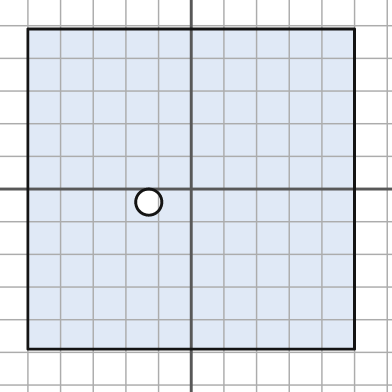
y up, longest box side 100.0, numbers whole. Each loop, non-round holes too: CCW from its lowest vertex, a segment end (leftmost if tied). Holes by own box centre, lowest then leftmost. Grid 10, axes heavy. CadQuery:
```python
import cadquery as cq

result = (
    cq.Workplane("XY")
    .moveTo(-50.0, -49.0)
    .lineTo(50.0, -49.0)
    .lineTo(50.0, 49.0)
    .lineTo(-50.0, 49.0)
    .close()
    .moveTo(-13.0, -4.0)
    .circle(4.0)
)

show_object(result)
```